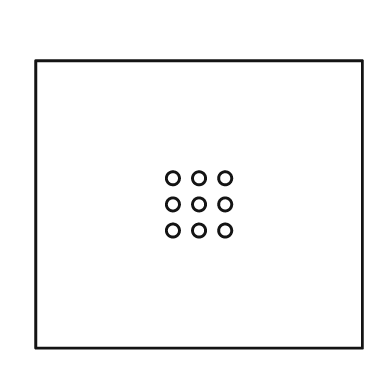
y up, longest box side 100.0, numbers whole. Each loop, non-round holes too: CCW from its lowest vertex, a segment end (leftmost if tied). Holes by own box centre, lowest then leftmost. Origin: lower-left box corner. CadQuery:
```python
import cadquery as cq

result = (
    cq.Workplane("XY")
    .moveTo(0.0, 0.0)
    .lineTo(100.0, 0.0)
    .lineTo(100.0, 88.0)
    .lineTo(0.0, 88.0)
    .close()
    .moveTo(42.0, 36.0)
    .circle(2.0)
    .moveTo(50.0, 36.0)
    .circle(2.0)
    .moveTo(58.0, 36.0)
    .circle(2.0)
    .moveTo(42.0, 44.0)
    .circle(2.0)
    .moveTo(50.0, 44.0)
    .circle(2.0)
    .moveTo(58.0, 44.0)
    .circle(2.0)
    .moveTo(42.0, 52.0)
    .circle(2.0)
    .moveTo(50.0, 52.0)
    .circle(2.0)
    .moveTo(58.0, 52.0)
    .circle(2.0)
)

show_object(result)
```